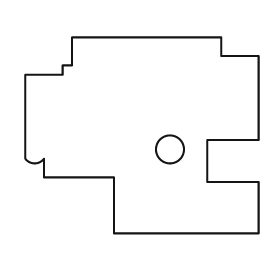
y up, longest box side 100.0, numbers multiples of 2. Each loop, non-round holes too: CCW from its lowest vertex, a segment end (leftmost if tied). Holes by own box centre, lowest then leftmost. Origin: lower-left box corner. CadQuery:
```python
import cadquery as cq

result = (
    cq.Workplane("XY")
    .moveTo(38.0, 0.0)
    .lineTo(100.0, 0.0)
    .lineTo(100.0, 22.0)
    .lineTo(78.0, 22.0)
    .lineTo(78.0, 40.0)
    .lineTo(100.0, 40.0)
    .lineTo(100.0, 76.0)
    .lineTo(84.0, 76.0)
    .lineTo(84.0, 84.0)
    .lineTo(20.0, 84.0)
    .lineTo(20.0, 72.0)
    .lineTo(16.0, 72.0)
    .lineTo(16.0, 68.0)
    .lineTo(0.0, 68.0)
    .lineTo(0.0, 32.0)
    .threePointArc((4.0, 30.0), (8.0, 32.0))
    .lineTo(8.0, 24.0)
    .lineTo(38.0, 24.0)
    .close()
    .moveTo(62.0, 36.0)
    .circle(6.0)
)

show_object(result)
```